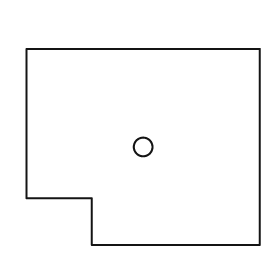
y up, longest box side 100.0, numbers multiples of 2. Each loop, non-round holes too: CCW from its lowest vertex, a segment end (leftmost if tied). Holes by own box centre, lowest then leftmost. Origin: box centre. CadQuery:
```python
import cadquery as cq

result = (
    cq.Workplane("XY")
    .moveTo(-22.0, -42.0)
    .lineTo(50.0, -42.0)
    .lineTo(50.0, 42.0)
    .lineTo(-50.0, 42.0)
    .lineTo(-50.0, -22.0)
    .lineTo(-22.0, -22.0)
    .close()
    .moveTo(0.0, 0.0)
    .circle(4.0)
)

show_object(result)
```